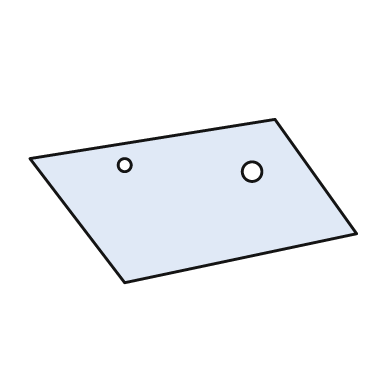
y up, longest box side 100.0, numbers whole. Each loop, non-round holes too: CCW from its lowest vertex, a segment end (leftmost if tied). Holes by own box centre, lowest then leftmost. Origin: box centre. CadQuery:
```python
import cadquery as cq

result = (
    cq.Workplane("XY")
    .moveTo(-21.0, -25.0)
    .lineTo(50.0, -10.0)
    .lineTo(25.0, 25.0)
    .lineTo(-50.0, 13.0)
    .close()
    .moveTo(18.0, 9.0)
    .circle(3.0)
    .moveTo(-21.0, 11.0)
    .circle(2.0)
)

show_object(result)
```